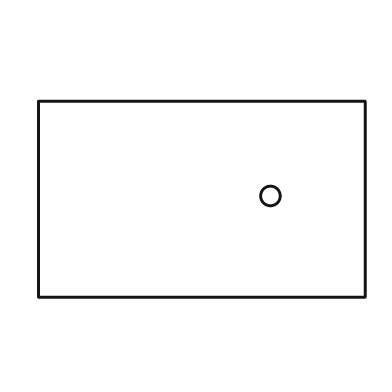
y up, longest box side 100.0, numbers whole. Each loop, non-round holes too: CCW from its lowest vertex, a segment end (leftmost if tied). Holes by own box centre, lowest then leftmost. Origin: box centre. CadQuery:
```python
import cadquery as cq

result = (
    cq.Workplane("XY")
    .moveTo(-50.0, -30.0)
    .lineTo(50.0, -30.0)
    .lineTo(50.0, 30.0)
    .lineTo(-50.0, 30.0)
    .close()
    .moveTo(21.0, 1.0)
    .circle(3.0)
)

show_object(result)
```